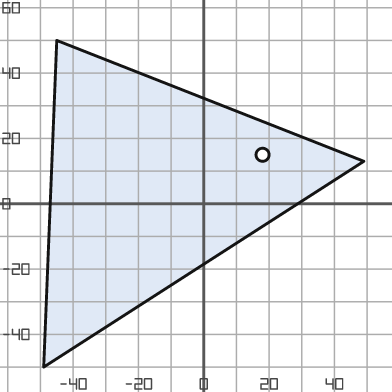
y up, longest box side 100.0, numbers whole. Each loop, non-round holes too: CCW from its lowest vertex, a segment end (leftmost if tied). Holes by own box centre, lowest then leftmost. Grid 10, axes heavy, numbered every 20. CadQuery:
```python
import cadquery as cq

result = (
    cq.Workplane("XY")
    .moveTo(-49.0, -50.0)
    .lineTo(49.0, 13.0)
    .lineTo(-45.0, 50.0)
    .close()
    .moveTo(18.0, 15.0)
    .circle(2.0)
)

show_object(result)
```